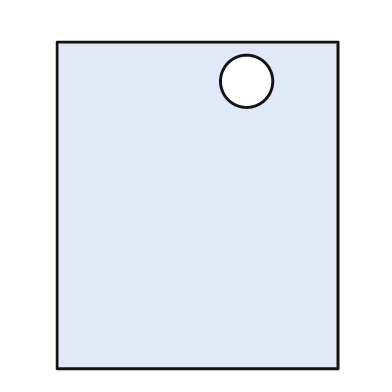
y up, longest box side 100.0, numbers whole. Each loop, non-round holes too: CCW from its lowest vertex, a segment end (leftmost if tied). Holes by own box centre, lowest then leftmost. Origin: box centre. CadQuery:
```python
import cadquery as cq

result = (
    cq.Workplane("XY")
    .moveTo(-43.0, -50.0)
    .lineTo(43.0, -50.0)
    .lineTo(43.0, 50.0)
    .lineTo(-43.0, 50.0)
    .close()
    .moveTo(15.0, 38.0)
    .circle(8.0)
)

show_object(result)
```